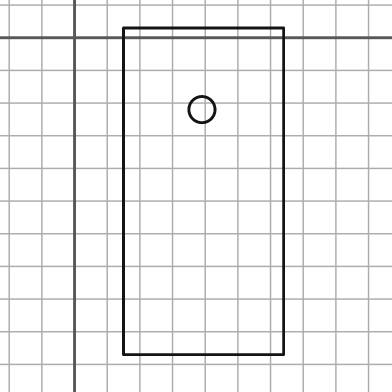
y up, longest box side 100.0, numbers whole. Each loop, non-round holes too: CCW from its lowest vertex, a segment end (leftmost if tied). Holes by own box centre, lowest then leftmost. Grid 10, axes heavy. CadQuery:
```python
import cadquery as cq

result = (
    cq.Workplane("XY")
    .moveTo(15.0, -97.0)
    .lineTo(64.0, -97.0)
    .lineTo(64.0, 3.0)
    .lineTo(15.0, 3.0)
    .close()
    .moveTo(39.0, -22.0)
    .circle(4.0)
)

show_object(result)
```